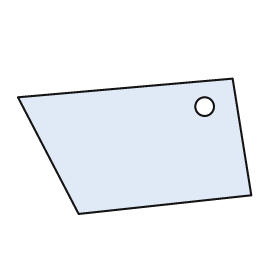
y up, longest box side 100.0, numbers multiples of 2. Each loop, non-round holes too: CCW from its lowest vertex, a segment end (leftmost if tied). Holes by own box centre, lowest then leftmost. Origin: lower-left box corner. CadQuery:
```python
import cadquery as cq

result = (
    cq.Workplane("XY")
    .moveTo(26.0, 0.0)
    .lineTo(100.0, 8.0)
    .lineTo(92.0, 58.0)
    .lineTo(0.0, 50.0)
    .close()
    .moveTo(80.0, 46.0)
    .circle(4.0)
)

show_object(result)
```